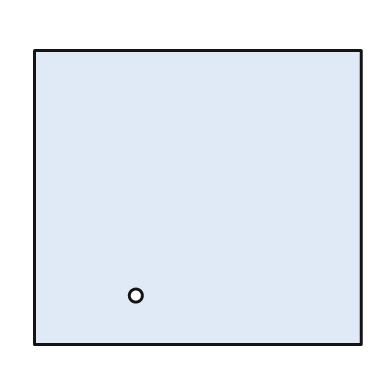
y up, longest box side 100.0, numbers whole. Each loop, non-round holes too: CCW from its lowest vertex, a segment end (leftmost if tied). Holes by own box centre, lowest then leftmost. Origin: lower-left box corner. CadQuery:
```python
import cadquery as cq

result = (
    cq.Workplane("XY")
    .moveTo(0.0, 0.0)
    .lineTo(100.0, 0.0)
    .lineTo(100.0, 90.0)
    .lineTo(0.0, 90.0)
    .close()
    .moveTo(31.0, 15.0)
    .circle(2.0)
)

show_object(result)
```